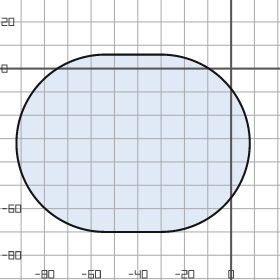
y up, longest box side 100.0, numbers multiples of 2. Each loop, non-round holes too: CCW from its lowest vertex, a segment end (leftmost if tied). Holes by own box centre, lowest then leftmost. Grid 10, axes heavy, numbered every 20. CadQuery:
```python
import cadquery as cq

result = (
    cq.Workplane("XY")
    .moveTo(-54.0, -70.0)
    .lineTo(-30.0, -70.0)
    .threePointArc((8.0, -32.0), (-30.0, 6.0))
    .lineTo(-54.0, 6.0)
    .threePointArc((-92.0, -32.0), (-54.0, -70.0))
    .close()
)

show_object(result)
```